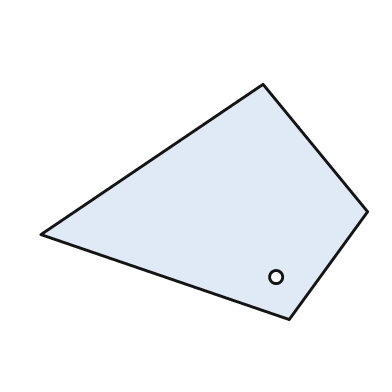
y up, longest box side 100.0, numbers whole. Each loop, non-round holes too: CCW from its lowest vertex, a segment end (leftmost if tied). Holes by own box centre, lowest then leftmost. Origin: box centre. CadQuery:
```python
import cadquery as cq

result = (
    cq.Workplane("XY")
    .moveTo(26.0, -36.0)
    .lineTo(50.0, -3.0)
    .lineTo(18.0, 36.0)
    .lineTo(-50.0, -10.0)
    .close()
    .moveTo(22.0, -23.0)
    .circle(2.0)
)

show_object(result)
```